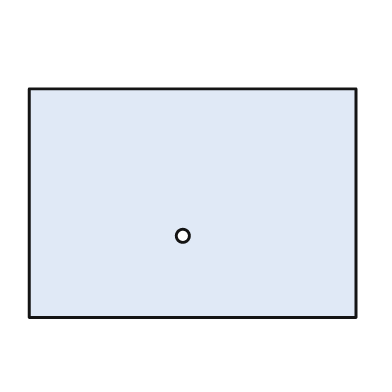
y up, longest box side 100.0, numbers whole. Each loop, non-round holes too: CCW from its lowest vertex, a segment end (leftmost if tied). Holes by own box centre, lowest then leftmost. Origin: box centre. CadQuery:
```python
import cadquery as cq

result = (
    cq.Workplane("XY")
    .moveTo(-50.0, -35.0)
    .lineTo(50.0, -35.0)
    .lineTo(50.0, 35.0)
    .lineTo(-50.0, 35.0)
    .close()
    .moveTo(-3.0, -10.0)
    .circle(2.0)
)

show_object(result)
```